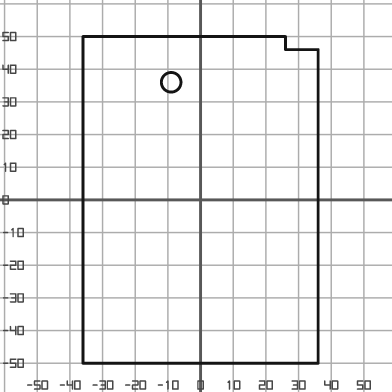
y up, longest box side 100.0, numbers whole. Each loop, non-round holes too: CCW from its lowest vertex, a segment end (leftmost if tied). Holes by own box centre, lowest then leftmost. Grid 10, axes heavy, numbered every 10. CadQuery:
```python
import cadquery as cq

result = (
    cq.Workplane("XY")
    .moveTo(-36.0, -50.0)
    .lineTo(36.0, -50.0)
    .lineTo(36.0, 46.0)
    .lineTo(26.0, 46.0)
    .lineTo(26.0, 50.0)
    .lineTo(-36.0, 50.0)
    .close()
    .moveTo(-9.0, 36.0)
    .circle(3.0)
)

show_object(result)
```